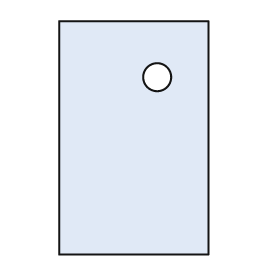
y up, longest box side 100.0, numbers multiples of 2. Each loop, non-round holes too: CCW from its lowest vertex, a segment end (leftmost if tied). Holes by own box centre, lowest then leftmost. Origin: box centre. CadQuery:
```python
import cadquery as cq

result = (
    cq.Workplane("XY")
    .moveTo(-32.0, -50.0)
    .lineTo(32.0, -50.0)
    .lineTo(32.0, 50.0)
    .lineTo(-32.0, 50.0)
    .close()
    .moveTo(10.0, 26.0)
    .circle(6.0)
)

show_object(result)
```